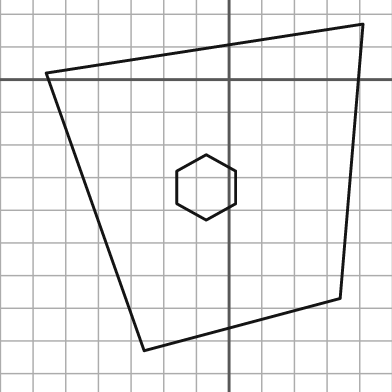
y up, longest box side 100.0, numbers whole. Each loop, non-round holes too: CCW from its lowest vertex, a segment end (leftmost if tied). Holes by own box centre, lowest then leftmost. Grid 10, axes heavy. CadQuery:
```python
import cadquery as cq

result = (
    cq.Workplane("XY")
    .moveTo(-26.0, -83.0)
    .lineTo(34.0, -67.0)
    .lineTo(41.0, 17.0)
    .lineTo(-56.0, 2.0)
    .close()
    .moveTo(-7.0, -43.0)
    .lineTo(2.0, -38.0)
    .lineTo(2.0, -28.0)
    .lineTo(-7.0, -23.0)
    .lineTo(-16.0, -28.0)
    .lineTo(-16.0, -38.0)
    .close()
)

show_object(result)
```